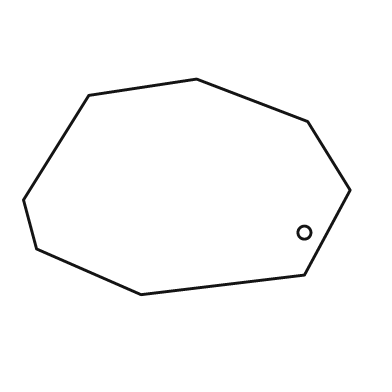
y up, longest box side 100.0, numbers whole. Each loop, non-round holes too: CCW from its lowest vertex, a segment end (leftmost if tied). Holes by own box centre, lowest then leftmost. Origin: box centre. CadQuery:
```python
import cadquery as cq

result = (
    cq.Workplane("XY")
    .moveTo(-14.0, -33.0)
    .lineTo(36.0, -27.0)
    .lineTo(50.0, -1.0)
    .lineTo(37.0, 20.0)
    .lineTo(3.0, 33.0)
    .lineTo(-30.0, 28.0)
    .lineTo(-50.0, -4.0)
    .lineTo(-46.0, -19.0)
    .close()
    .moveTo(36.0, -14.0)
    .circle(2.0)
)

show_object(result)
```